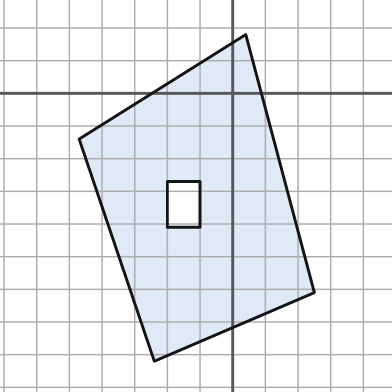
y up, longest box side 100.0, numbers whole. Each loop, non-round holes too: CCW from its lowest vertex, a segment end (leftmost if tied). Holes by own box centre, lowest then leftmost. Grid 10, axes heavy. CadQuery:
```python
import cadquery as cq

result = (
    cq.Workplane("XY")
    .moveTo(-24.0, -82.0)
    .lineTo(25.0, -61.0)
    .lineTo(4.0, 18.0)
    .lineTo(-47.0, -14.0)
    .close()
    .moveTo(-20.0, -41.0)
    .lineTo(-10.0, -41.0)
    .lineTo(-10.0, -27.0)
    .lineTo(-20.0, -27.0)
    .close()
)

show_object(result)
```